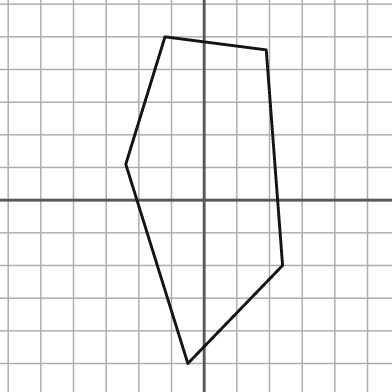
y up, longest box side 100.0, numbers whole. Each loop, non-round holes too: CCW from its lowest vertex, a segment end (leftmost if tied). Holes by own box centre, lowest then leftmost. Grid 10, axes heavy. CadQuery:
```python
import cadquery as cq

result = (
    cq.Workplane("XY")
    .moveTo(-5.0, -50.0)
    .lineTo(24.0, -20.0)
    .lineTo(19.0, 46.0)
    .lineTo(-12.0, 50.0)
    .lineTo(-24.0, 11.0)
    .close()
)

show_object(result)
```